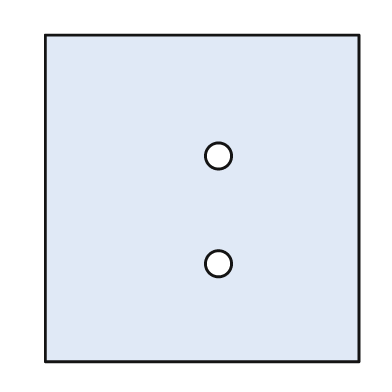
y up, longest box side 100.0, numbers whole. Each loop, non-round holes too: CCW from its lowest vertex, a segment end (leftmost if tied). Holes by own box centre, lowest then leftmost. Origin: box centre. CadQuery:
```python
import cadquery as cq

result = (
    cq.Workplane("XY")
    .moveTo(-48.0, -50.0)
    .lineTo(48.0, -50.0)
    .lineTo(48.0, 50.0)
    .lineTo(-48.0, 50.0)
    .close()
    .moveTo(5.0, -20.0)
    .circle(4.0)
    .moveTo(5.0, 13.0)
    .circle(4.0)
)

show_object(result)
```